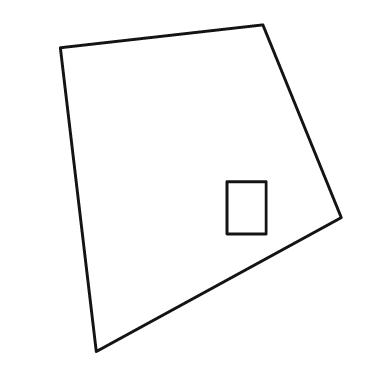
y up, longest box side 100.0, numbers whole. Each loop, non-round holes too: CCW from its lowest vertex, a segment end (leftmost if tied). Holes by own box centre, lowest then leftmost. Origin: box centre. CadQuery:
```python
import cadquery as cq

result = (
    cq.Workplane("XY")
    .moveTo(-32.0, -50.0)
    .lineTo(43.0, -9.0)
    .lineTo(19.0, 50.0)
    .lineTo(-43.0, 43.0)
    .close()
    .moveTo(8.0, -14.0)
    .lineTo(20.0, -14.0)
    .lineTo(20.0, 2.0)
    .lineTo(8.0, 2.0)
    .close()
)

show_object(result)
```